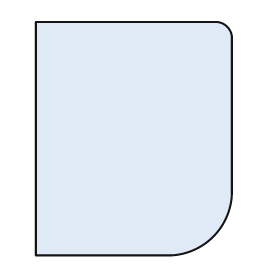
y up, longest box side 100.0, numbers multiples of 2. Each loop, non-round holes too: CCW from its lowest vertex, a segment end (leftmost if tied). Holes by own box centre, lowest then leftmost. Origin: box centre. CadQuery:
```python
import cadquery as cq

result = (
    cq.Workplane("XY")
    .moveTo(-42.0, -50.0)
    .lineTo(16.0, -50.0)
    .threePointArc((34.0, -42.0), (42.0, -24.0))
    .lineTo(42.0, 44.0)
    .threePointArc((40.0, 48.0), (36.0, 50.0))
    .lineTo(-42.0, 50.0)
    .close()
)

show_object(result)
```